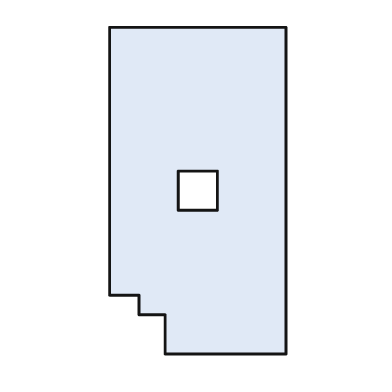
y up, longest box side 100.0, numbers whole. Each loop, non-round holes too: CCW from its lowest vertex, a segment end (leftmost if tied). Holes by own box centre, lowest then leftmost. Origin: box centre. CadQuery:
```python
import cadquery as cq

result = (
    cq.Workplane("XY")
    .moveTo(-10.0, -50.0)
    .lineTo(27.0, -50.0)
    .lineTo(27.0, 50.0)
    .lineTo(-27.0, 50.0)
    .lineTo(-27.0, -32.0)
    .lineTo(-18.0, -32.0)
    .lineTo(-18.0, -38.0)
    .lineTo(-10.0, -38.0)
    .close()
    .moveTo(-6.0, -6.0)
    .lineTo(6.0, -6.0)
    .lineTo(6.0, 6.0)
    .lineTo(-6.0, 6.0)
    .close()
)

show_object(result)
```